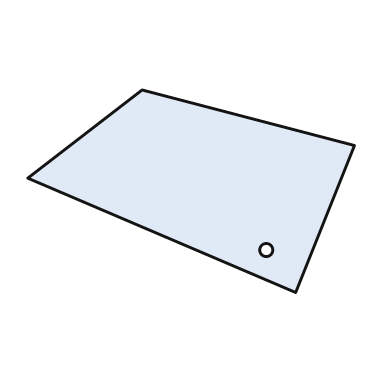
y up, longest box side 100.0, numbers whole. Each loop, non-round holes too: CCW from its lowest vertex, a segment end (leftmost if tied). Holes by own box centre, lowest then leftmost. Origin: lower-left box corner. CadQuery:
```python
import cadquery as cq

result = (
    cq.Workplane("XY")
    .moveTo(82.0, 0.0)
    .lineTo(100.0, 45.0)
    .lineTo(35.0, 62.0)
    .lineTo(0.0, 35.0)
    .close()
    .moveTo(73.0, 13.0)
    .circle(2.0)
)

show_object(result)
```